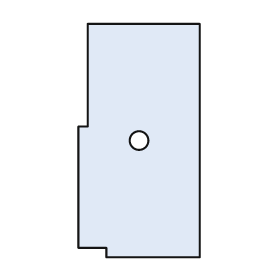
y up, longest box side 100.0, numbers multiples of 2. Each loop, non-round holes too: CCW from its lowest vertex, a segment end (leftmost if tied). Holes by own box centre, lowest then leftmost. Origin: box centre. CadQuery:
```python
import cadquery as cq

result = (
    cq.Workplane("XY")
    .moveTo(-14.0, -50.0)
    .lineTo(26.0, -50.0)
    .lineTo(26.0, 50.0)
    .lineTo(-22.0, 50.0)
    .lineTo(-22.0, 6.0)
    .lineTo(-26.0, 6.0)
    .lineTo(-26.0, -46.0)
    .lineTo(-14.0, -46.0)
    .close()
    .moveTo(0.0, 0.0)
    .circle(4.0)
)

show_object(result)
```